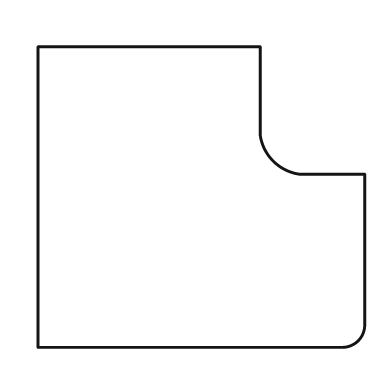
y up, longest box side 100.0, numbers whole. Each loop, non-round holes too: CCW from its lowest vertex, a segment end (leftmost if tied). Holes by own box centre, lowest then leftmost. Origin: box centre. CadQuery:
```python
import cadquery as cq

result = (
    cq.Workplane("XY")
    .moveTo(-50.0, -46.0)
    .lineTo(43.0, -46.0)
    .threePointArc((48.0, -44.0), (50.0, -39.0))
    .lineTo(50.0, 7.0)
    .lineTo(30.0, 7.0)
    .threePointArc((22.0, 11.0), (18.0, 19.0))
    .lineTo(18.0, 46.0)
    .lineTo(-50.0, 46.0)
    .close()
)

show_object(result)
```